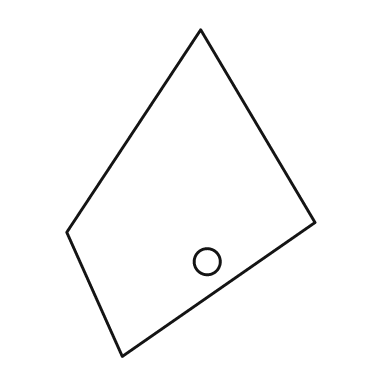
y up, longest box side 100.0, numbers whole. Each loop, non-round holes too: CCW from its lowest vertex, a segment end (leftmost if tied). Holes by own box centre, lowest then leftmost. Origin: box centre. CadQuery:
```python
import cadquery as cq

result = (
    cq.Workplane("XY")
    .moveTo(-21.0, -50.0)
    .lineTo(38.0, -9.0)
    .lineTo(3.0, 50.0)
    .lineTo(-38.0, -12.0)
    .close()
    .moveTo(5.0, -21.0)
    .circle(4.0)
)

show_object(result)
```